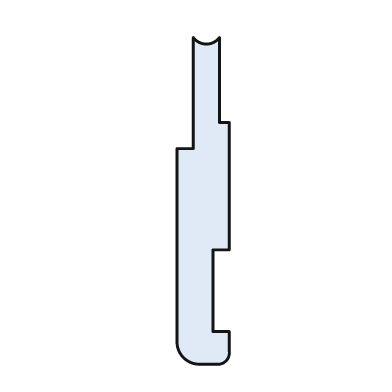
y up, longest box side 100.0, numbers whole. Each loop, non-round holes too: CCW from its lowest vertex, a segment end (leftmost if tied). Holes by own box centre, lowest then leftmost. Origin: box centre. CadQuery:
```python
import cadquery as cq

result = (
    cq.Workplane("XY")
    .moveTo(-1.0, -50.0)
    .lineTo(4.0, -50.0)
    .threePointArc((7.0, -49.0), (8.0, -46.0))
    .lineTo(8.0, -40.0)
    .lineTo(3.0, -40.0)
    .lineTo(3.0, -15.0)
    .lineTo(8.0, -15.0)
    .lineTo(8.0, 24.0)
    .lineTo(5.0, 24.0)
    .lineTo(5.0, 50.0)
    .threePointArc((1.0, 48.0), (-3.0, 50.0))
    .lineTo(-3.0, 16.0)
    .lineTo(-8.0, 16.0)
    .lineTo(-8.0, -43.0)
    .threePointArc((-6.0, -48.0), (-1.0, -50.0))
    .close()
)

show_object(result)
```